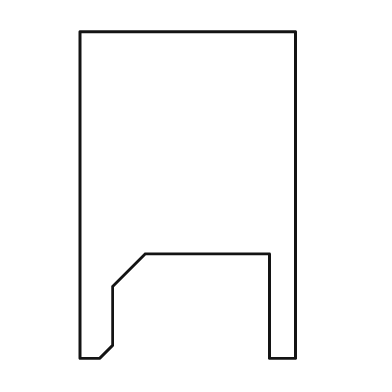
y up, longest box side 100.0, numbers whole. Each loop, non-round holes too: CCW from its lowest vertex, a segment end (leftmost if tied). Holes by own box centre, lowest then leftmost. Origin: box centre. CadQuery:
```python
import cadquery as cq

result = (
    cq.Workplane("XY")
    .moveTo(-33.0, -50.0)
    .lineTo(-27.0, -50.0)
    .lineTo(-23.0, -46.0)
    .lineTo(-23.0, -28.0)
    .lineTo(-13.0, -18.0)
    .lineTo(25.0, -18.0)
    .lineTo(25.0, -50.0)
    .lineTo(33.0, -50.0)
    .lineTo(33.0, 50.0)
    .lineTo(-33.0, 50.0)
    .close()
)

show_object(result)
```